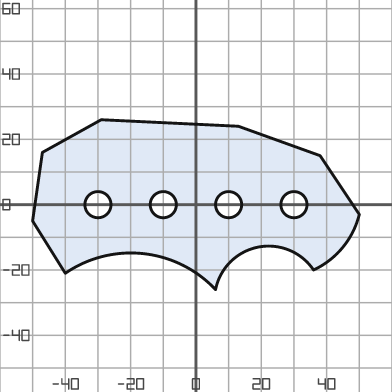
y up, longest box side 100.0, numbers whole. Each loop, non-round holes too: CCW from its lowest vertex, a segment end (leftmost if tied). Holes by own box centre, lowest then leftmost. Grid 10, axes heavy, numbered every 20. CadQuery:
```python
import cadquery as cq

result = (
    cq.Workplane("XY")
    .moveTo(6.0, -26.0)
    .threePointArc((19.0, -13.0), (36.0, -20.0))
    .threePointArc((45.0, -13.0), (50.0, -3.0))
    .lineTo(38.0, 15.0)
    .lineTo(13.0, 24.0)
    .lineTo(-29.0, 26.0)
    .lineTo(-47.0, 16.0)
    .lineTo(-50.0, -5.0)
    .lineTo(-40.0, -21.0)
    .threePointArc((-16.0, -15.0), (6.0, -26.0))
    .close()
    .moveTo(-30.0, 0.0)
    .circle(4.0)
    .moveTo(-10.0, 0.0)
    .circle(4.0)
    .moveTo(10.0, 0.0)
    .circle(4.0)
    .moveTo(30.0, 0.0)
    .circle(4.0)
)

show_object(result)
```